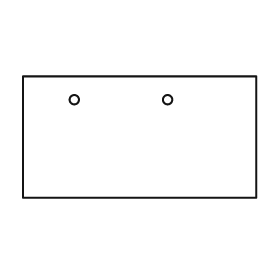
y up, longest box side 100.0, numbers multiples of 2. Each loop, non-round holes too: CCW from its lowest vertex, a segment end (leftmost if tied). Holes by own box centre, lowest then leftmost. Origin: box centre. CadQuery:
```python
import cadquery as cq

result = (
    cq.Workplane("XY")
    .moveTo(-50.0, -26.0)
    .lineTo(50.0, -26.0)
    .lineTo(50.0, 26.0)
    .lineTo(-50.0, 26.0)
    .close()
    .moveTo(-28.0, 16.0)
    .circle(2.0)
    .moveTo(12.0, 16.0)
    .circle(2.0)
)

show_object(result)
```